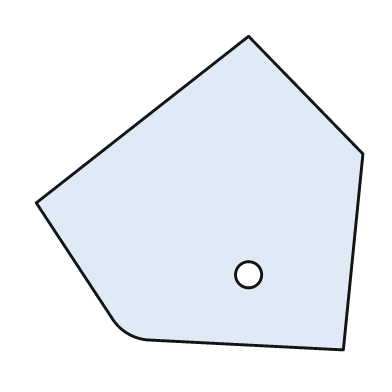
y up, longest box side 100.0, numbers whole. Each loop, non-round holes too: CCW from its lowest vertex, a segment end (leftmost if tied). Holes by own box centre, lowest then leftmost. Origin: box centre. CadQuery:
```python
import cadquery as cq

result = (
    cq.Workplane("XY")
    .moveTo(44.0, -48.0)
    .lineTo(50.0, 12.0)
    .lineTo(15.0, 48.0)
    .lineTo(-50.0, -3.0)
    .lineTo(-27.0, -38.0)
    .threePointArc((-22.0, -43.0), (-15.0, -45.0))
    .close()
    .moveTo(15.0, -25.0)
    .circle(4.0)
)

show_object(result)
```